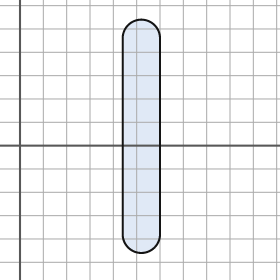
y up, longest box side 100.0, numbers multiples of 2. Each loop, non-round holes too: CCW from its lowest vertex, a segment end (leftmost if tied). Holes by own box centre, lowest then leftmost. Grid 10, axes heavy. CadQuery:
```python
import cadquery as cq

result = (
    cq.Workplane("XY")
    .moveTo(44.0, -38.0)
    .threePointArc((52.0, -46.0), (60.0, -38.0))
    .lineTo(60.0, 46.0)
    .threePointArc((52.0, 54.0), (44.0, 46.0))
    .close()
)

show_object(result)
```